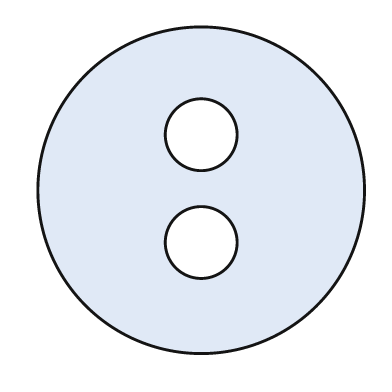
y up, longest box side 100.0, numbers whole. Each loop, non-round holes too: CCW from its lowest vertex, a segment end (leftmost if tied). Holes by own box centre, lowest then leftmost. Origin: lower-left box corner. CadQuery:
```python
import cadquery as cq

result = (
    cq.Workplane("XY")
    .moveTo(50.0, 50.0)
    .circle(50.0)
    .moveTo(50.0, 34.0)
    .circle(11.0)
    .moveTo(50.0, 67.0)
    .circle(11.0)
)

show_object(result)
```